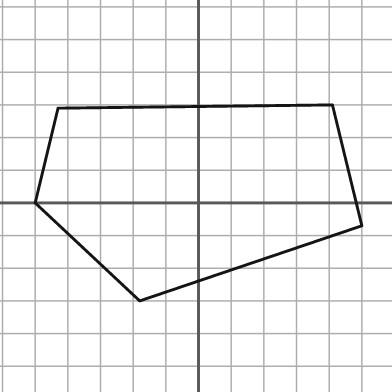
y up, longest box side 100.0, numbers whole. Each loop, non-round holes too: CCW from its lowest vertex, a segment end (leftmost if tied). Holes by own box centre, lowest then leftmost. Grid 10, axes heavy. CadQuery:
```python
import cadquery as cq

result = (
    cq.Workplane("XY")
    .moveTo(-18.0, -30.0)
    .lineTo(50.0, -7.0)
    .lineTo(41.0, 30.0)
    .lineTo(-43.0, 29.0)
    .lineTo(-50.0, 0.0)
    .close()
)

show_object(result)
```